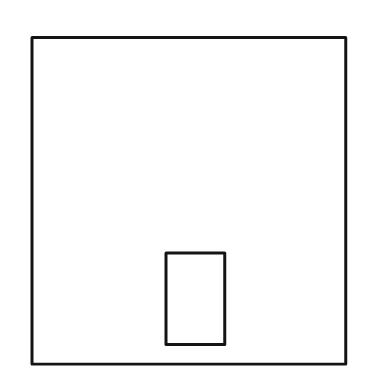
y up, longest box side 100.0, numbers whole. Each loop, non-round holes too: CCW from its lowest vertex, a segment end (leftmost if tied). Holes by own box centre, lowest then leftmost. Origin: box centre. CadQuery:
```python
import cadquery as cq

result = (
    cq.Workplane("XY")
    .moveTo(-48.0, -50.0)
    .lineTo(48.0, -50.0)
    .lineTo(48.0, 50.0)
    .lineTo(-48.0, 50.0)
    .close()
    .moveTo(-7.0, -44.0)
    .lineTo(11.0, -44.0)
    .lineTo(11.0, -16.0)
    .lineTo(-7.0, -16.0)
    .close()
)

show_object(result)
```